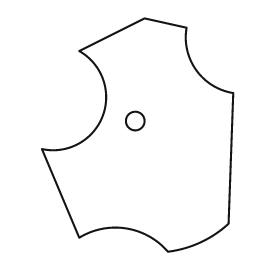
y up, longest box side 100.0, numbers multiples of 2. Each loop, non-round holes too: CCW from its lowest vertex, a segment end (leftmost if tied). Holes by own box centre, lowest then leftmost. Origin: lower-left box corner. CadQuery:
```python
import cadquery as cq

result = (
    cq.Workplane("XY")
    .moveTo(54.0, 0.0)
    .threePointArc((68.0, 4.0), (80.0, 12.0))
    .lineTo(82.0, 68.0)
    .threePointArc((66.0, 78.0), (62.0, 96.0))
    .lineTo(44.0, 100.0)
    .lineTo(16.0, 86.0)
    .threePointArc((26.0, 58.0), (0.0, 44.0))
    .lineTo(16.0, 6.0)
    .threePointArc((36.0, 10.0), (54.0, 0.0))
    .close()
    .moveTo(40.0, 56.0)
    .circle(4.0)
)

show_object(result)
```